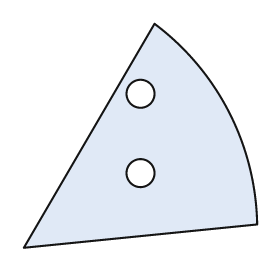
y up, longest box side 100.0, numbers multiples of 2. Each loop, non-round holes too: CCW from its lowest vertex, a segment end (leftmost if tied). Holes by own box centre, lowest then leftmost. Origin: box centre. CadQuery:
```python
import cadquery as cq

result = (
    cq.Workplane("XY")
    .moveTo(-50.0, -48.0)
    .lineTo(50.0, -38.0)
    .threePointArc((38.0, 10.0), (6.0, 48.0))
    .close()
    .moveTo(0.0, -16.0)
    .circle(6.0)
    .moveTo(0.0, 18.0)
    .circle(6.0)
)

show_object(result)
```